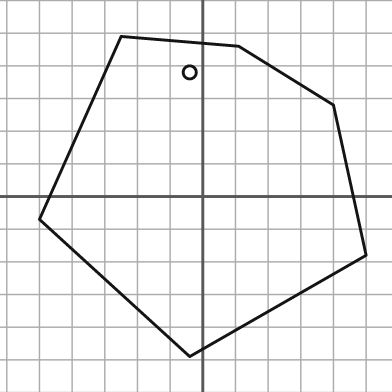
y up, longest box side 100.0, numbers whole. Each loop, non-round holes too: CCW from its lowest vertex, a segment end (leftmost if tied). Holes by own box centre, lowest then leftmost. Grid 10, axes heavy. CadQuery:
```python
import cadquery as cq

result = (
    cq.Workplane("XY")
    .moveTo(-4.0, -49.0)
    .lineTo(50.0, -18.0)
    .lineTo(40.0, 28.0)
    .lineTo(11.0, 46.0)
    .lineTo(-25.0, 49.0)
    .lineTo(-50.0, -7.0)
    .close()
    .moveTo(-4.0, 38.0)
    .circle(2.0)
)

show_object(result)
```